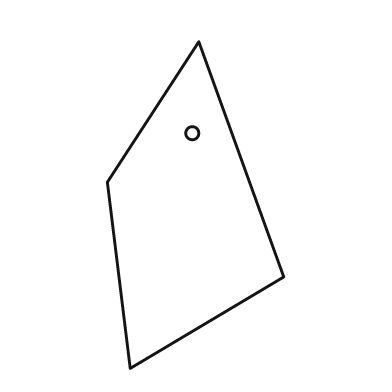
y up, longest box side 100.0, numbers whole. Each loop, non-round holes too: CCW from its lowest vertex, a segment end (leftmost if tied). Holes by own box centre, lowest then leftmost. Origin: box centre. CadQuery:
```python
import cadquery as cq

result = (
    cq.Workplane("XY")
    .moveTo(-20.0, -50.0)
    .lineTo(27.0, -22.0)
    .lineTo(1.0, 50.0)
    .lineTo(-27.0, 7.0)
    .close()
    .moveTo(-1.0, 22.0)
    .circle(2.0)
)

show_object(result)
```